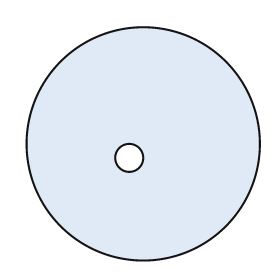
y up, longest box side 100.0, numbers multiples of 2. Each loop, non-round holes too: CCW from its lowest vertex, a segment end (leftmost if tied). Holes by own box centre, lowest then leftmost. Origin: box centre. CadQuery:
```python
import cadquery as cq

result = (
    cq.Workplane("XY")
    .moveTo(0.0, 0.0)
    .circle(50.0)
    .moveTo(-6.0, -6.0)
    .circle(6.0)
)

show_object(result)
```